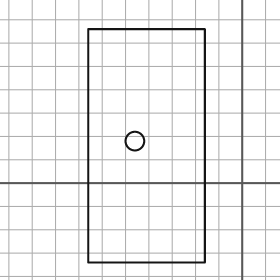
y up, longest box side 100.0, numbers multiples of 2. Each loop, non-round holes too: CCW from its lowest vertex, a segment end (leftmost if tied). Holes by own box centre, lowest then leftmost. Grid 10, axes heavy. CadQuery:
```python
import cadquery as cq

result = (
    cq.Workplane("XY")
    .moveTo(-66.0, -34.0)
    .lineTo(-16.0, -34.0)
    .lineTo(-16.0, 66.0)
    .lineTo(-66.0, 66.0)
    .close()
    .moveTo(-46.0, 18.0)
    .circle(4.0)
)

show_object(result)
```